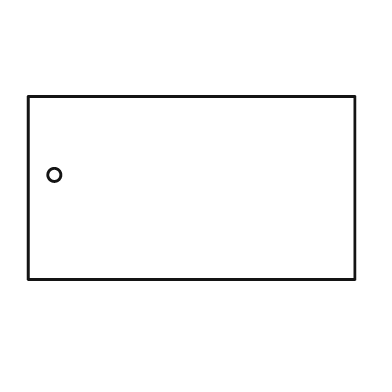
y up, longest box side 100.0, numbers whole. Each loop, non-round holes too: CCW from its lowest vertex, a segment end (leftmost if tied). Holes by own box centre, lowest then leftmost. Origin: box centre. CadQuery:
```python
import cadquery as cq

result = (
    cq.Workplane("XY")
    .moveTo(-50.0, -28.0)
    .lineTo(50.0, -28.0)
    .lineTo(50.0, 28.0)
    .lineTo(-50.0, 28.0)
    .close()
    .moveTo(-42.0, 4.0)
    .circle(2.0)
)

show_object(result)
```